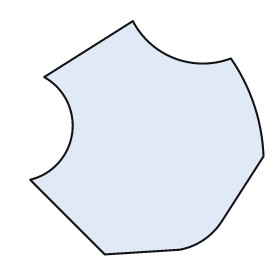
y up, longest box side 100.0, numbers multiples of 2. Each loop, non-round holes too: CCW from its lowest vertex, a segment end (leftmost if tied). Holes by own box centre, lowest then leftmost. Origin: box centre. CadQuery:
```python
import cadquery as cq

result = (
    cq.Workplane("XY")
    .moveTo(-18.0, -50.0)
    .lineTo(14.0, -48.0)
    .threePointArc((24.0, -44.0), (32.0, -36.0))
    .lineTo(50.0, -8.0)
    .threePointArc((46.0, 14.0), (36.0, 34.0))
    .threePointArc((12.0, 34.0), (-6.0, 50.0))
    .lineTo(-44.0, 26.0)
    .threePointArc((-32.0, 2.0), (-50.0, -18.0))
    .close()
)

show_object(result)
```